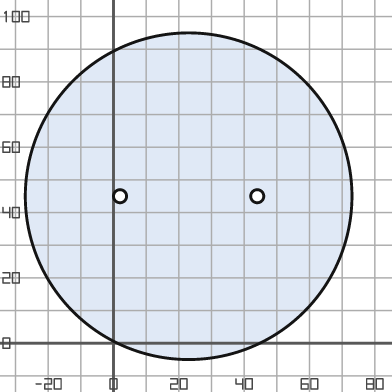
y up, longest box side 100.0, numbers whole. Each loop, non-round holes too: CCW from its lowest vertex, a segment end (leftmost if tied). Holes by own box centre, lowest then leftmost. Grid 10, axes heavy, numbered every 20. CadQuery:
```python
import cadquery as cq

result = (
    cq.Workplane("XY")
    .moveTo(23.0, 45.0)
    .circle(50.0)
    .moveTo(2.0, 45.0)
    .circle(2.0)
    .moveTo(44.0, 45.0)
    .circle(2.0)
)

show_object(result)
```